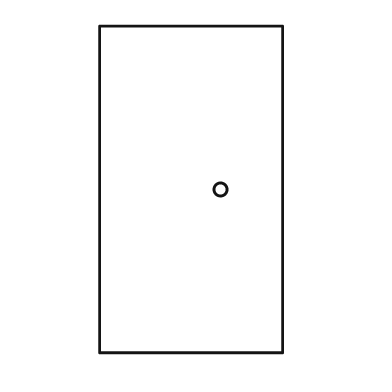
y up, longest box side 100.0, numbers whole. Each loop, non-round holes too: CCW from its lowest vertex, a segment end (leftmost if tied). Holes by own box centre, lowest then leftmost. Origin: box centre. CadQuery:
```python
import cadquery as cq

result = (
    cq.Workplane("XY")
    .moveTo(-28.0, -50.0)
    .lineTo(28.0, -50.0)
    .lineTo(28.0, 50.0)
    .lineTo(-28.0, 50.0)
    .close()
    .moveTo(9.0, 0.0)
    .circle(2.0)
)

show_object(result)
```